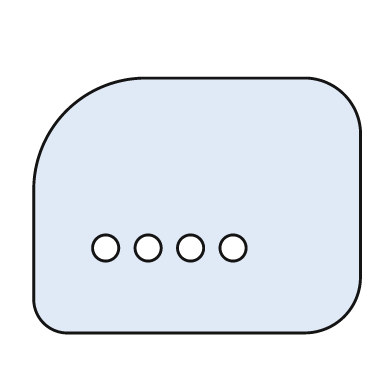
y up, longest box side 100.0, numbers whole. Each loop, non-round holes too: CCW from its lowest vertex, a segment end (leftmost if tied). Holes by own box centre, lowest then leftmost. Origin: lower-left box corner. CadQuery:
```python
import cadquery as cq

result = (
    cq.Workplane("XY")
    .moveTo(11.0, 0.0)
    .lineTo(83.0, 0.0)
    .threePointArc((95.0, 5.0), (100.0, 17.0))
    .lineTo(100.0, 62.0)
    .threePointArc((95.0, 73.0), (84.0, 78.0))
    .lineTo(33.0, 78.0)
    .threePointArc((10.0, 68.0), (0.0, 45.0))
    .lineTo(0.0, 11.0)
    .threePointArc((3.0, 3.0), (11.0, 0.0))
    .close()
    .moveTo(22.0, 26.0)
    .circle(4.0)
    .moveTo(35.0, 26.0)
    .circle(4.0)
    .moveTo(48.0, 26.0)
    .circle(4.0)
    .moveTo(61.0, 26.0)
    .circle(4.0)
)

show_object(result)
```